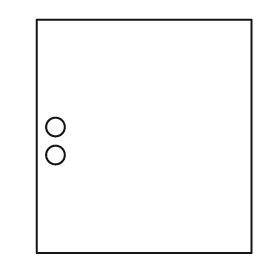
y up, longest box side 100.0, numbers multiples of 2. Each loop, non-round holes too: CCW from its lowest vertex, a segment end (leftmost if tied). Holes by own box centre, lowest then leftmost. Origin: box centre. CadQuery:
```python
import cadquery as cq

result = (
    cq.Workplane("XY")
    .moveTo(-46.0, -50.0)
    .lineTo(46.0, -50.0)
    .lineTo(46.0, 50.0)
    .lineTo(-46.0, 50.0)
    .close()
    .moveTo(-38.0, -8.0)
    .circle(4.0)
    .moveTo(-38.0, 4.0)
    .circle(4.0)
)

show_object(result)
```